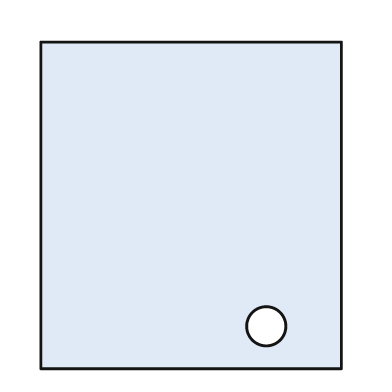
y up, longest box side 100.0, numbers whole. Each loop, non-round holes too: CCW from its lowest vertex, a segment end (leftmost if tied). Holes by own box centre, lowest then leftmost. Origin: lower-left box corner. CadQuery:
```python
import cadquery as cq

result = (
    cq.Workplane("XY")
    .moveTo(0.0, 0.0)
    .lineTo(92.0, 0.0)
    .lineTo(92.0, 100.0)
    .lineTo(0.0, 100.0)
    .close()
    .moveTo(69.0, 13.0)
    .circle(6.0)
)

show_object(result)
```